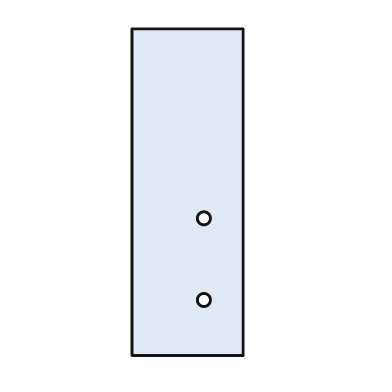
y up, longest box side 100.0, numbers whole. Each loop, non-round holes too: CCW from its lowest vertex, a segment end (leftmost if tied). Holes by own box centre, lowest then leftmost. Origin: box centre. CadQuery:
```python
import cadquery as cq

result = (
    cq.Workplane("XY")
    .moveTo(-17.0, -50.0)
    .lineTo(17.0, -50.0)
    .lineTo(17.0, 50.0)
    .lineTo(-17.0, 50.0)
    .close()
    .moveTo(5.0, -33.0)
    .circle(2.0)
    .moveTo(5.0, -8.0)
    .circle(2.0)
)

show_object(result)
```